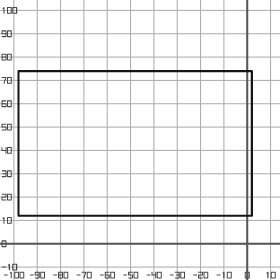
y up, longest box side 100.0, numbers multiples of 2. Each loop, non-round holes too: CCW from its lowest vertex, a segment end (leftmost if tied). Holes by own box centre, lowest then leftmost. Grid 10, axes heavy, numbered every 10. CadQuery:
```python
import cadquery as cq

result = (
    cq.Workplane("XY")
    .moveTo(-98.0, 12.0)
    .lineTo(2.0, 12.0)
    .lineTo(2.0, 74.0)
    .lineTo(-98.0, 74.0)
    .close()
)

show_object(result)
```